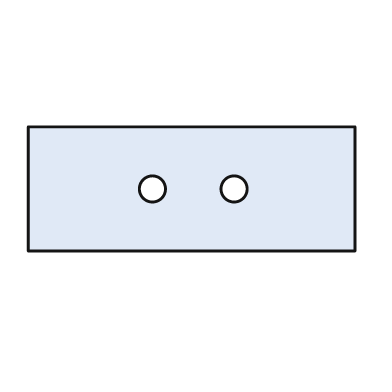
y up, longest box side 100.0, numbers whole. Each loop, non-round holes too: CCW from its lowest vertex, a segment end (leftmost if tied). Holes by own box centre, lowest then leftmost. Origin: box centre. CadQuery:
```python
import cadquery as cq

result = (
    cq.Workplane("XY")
    .moveTo(-50.0, -19.0)
    .lineTo(50.0, -19.0)
    .lineTo(50.0, 19.0)
    .lineTo(-50.0, 19.0)
    .close()
    .moveTo(-12.0, 0.0)
    .circle(4.0)
    .moveTo(13.0, 0.0)
    .circle(4.0)
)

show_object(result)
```